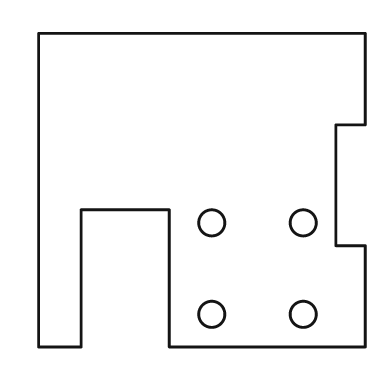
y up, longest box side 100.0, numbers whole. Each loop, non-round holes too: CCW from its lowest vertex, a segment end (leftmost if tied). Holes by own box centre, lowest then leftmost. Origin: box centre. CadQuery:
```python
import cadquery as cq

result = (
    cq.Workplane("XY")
    .moveTo(-50.0, -48.0)
    .lineTo(-37.0, -48.0)
    .lineTo(-37.0, -6.0)
    .lineTo(-10.0, -6.0)
    .lineTo(-10.0, -48.0)
    .lineTo(50.0, -48.0)
    .lineTo(50.0, -17.0)
    .lineTo(41.0, -17.0)
    .lineTo(41.0, 20.0)
    .lineTo(50.0, 20.0)
    .lineTo(50.0, 48.0)
    .lineTo(-50.0, 48.0)
    .close()
    .moveTo(3.0, -38.0)
    .circle(4.0)
    .moveTo(31.0, -38.0)
    .circle(4.0)
    .moveTo(3.0, -10.0)
    .circle(4.0)
    .moveTo(31.0, -10.0)
    .circle(4.0)
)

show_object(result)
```